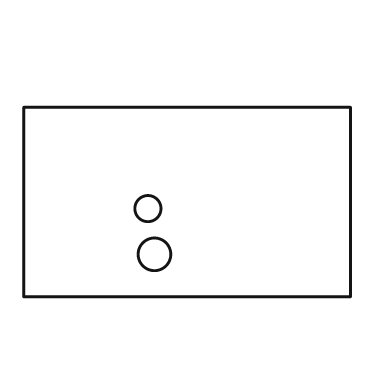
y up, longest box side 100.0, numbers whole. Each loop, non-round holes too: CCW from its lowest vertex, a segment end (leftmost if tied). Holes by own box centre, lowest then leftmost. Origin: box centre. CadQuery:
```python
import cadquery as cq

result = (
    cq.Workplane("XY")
    .moveTo(-50.0, -29.0)
    .lineTo(50.0, -29.0)
    .lineTo(50.0, 29.0)
    .lineTo(-50.0, 29.0)
    .close()
    .moveTo(-10.0, -16.0)
    .circle(5.0)
    .moveTo(-12.0, -2.0)
    .circle(4.0)
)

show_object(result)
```